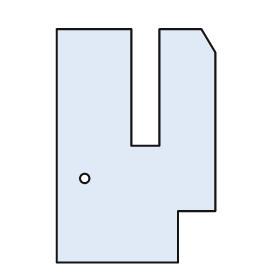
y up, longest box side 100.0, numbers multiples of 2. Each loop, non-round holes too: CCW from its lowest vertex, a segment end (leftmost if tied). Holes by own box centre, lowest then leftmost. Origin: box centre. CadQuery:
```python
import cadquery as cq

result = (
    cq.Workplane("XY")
    .moveTo(-34.0, -50.0)
    .lineTo(18.0, -50.0)
    .lineTo(18.0, -28.0)
    .lineTo(34.0, -28.0)
    .lineTo(34.0, 40.0)
    .lineTo(28.0, 50.0)
    .lineTo(10.0, 50.0)
    .lineTo(10.0, 0.0)
    .lineTo(-2.0, 0.0)
    .lineTo(-2.0, 50.0)
    .lineTo(-34.0, 50.0)
    .close()
    .moveTo(-22.0, -14.0)
    .circle(2.0)
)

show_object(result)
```